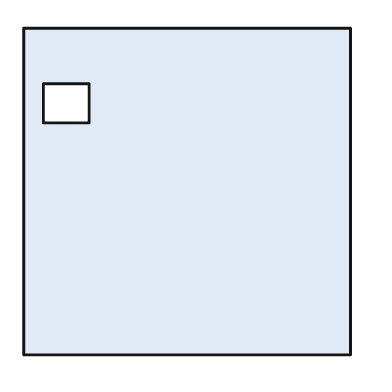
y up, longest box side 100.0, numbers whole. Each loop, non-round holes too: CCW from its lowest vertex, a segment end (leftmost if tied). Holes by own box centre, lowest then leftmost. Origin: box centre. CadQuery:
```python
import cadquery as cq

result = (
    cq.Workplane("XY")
    .moveTo(-50.0, -50.0)
    .lineTo(50.0, -50.0)
    .lineTo(50.0, 50.0)
    .lineTo(-50.0, 50.0)
    .close()
    .moveTo(-44.0, 21.0)
    .lineTo(-30.0, 21.0)
    .lineTo(-30.0, 33.0)
    .lineTo(-44.0, 33.0)
    .close()
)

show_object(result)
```